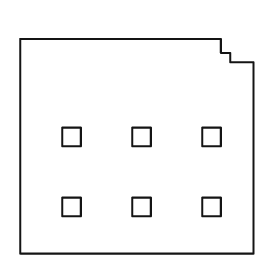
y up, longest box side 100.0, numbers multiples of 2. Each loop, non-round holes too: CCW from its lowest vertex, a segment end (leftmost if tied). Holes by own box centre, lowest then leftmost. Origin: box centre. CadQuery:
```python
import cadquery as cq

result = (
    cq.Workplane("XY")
    .moveTo(-50.0, -46.0)
    .lineTo(50.0, -46.0)
    .lineTo(50.0, 36.0)
    .lineTo(40.0, 36.0)
    .lineTo(40.0, 40.0)
    .lineTo(36.0, 40.0)
    .lineTo(36.0, 46.0)
    .lineTo(-50.0, 46.0)
    .close()
    .moveTo(-32.0, -30.0)
    .lineTo(-24.0, -30.0)
    .lineTo(-24.0, -22.0)
    .lineTo(-32.0, -22.0)
    .close()
    .moveTo(-2.0, -30.0)
    .lineTo(6.0, -30.0)
    .lineTo(6.0, -22.0)
    .lineTo(-2.0, -22.0)
    .close()
    .moveTo(28.0, -30.0)
    .lineTo(36.0, -30.0)
    .lineTo(36.0, -22.0)
    .lineTo(28.0, -22.0)
    .close()
    .moveTo(-32.0, 0.0)
    .lineTo(-24.0, 0.0)
    .lineTo(-24.0, 8.0)
    .lineTo(-32.0, 8.0)
    .close()
    .moveTo(-2.0, 0.0)
    .lineTo(6.0, 0.0)
    .lineTo(6.0, 8.0)
    .lineTo(-2.0, 8.0)
    .close()
    .moveTo(28.0, 0.0)
    .lineTo(36.0, 0.0)
    .lineTo(36.0, 8.0)
    .lineTo(28.0, 8.0)
    .close()
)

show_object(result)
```